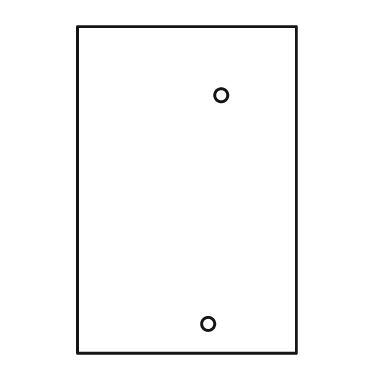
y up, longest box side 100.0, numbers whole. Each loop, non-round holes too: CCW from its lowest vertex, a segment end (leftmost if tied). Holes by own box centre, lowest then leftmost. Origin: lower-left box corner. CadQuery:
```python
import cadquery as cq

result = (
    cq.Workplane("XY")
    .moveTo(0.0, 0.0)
    .lineTo(67.0, 0.0)
    .lineTo(67.0, 100.0)
    .lineTo(0.0, 100.0)
    .close()
    .moveTo(40.0, 9.0)
    .circle(2.0)
    .moveTo(44.0, 79.0)
    .circle(2.0)
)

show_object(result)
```